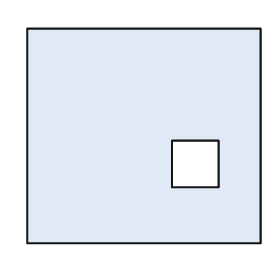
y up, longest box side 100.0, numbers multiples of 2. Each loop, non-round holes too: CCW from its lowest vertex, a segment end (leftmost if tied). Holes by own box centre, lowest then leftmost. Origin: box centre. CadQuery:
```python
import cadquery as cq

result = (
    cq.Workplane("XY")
    .moveTo(-50.0, -46.0)
    .lineTo(50.0, -46.0)
    .lineTo(50.0, 46.0)
    .lineTo(-50.0, 46.0)
    .close()
    .moveTo(12.0, -22.0)
    .lineTo(32.0, -22.0)
    .lineTo(32.0, -2.0)
    .lineTo(12.0, -2.0)
    .close()
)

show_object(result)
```